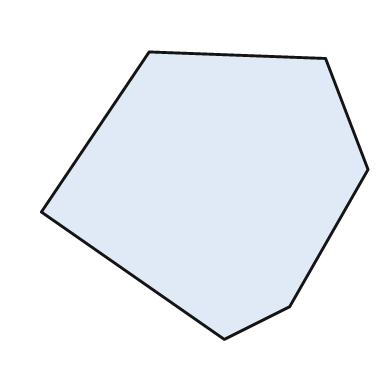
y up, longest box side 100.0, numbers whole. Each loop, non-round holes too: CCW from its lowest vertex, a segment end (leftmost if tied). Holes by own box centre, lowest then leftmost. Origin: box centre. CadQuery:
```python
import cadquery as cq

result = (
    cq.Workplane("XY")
    .moveTo(6.0, -44.0)
    .lineTo(26.0, -34.0)
    .lineTo(50.0, 8.0)
    .lineTo(37.0, 42.0)
    .lineTo(-17.0, 44.0)
    .lineTo(-50.0, -5.0)
    .close()
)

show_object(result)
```